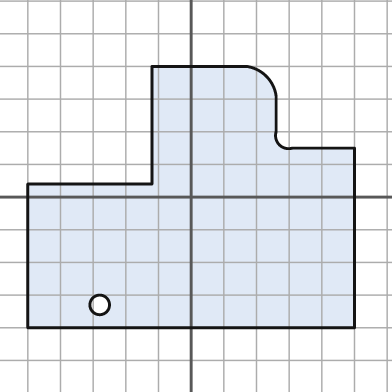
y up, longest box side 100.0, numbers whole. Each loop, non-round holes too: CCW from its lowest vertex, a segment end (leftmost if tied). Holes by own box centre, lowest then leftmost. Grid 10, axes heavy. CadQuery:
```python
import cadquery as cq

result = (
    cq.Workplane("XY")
    .moveTo(-50.0, -40.0)
    .lineTo(50.0, -40.0)
    .lineTo(50.0, 15.0)
    .lineTo(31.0, 15.0)
    .threePointArc((27.0, 16.0), (26.0, 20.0))
    .lineTo(26.0, 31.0)
    .threePointArc((23.0, 37.0), (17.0, 40.0))
    .lineTo(-12.0, 40.0)
    .lineTo(-12.0, 4.0)
    .lineTo(-50.0, 4.0)
    .close()
    .moveTo(-28.0, -33.0)
    .circle(3.0)
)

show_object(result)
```